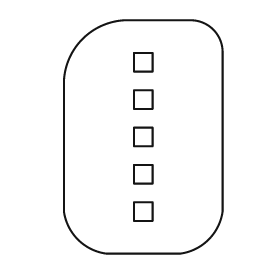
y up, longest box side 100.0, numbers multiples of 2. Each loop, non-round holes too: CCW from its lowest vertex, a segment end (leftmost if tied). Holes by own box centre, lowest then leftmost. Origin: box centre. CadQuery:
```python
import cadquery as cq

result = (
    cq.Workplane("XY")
    .moveTo(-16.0, -50.0)
    .lineTo(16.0, -50.0)
    .threePointArc((28.0, -44.0), (34.0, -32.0))
    .lineTo(34.0, 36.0)
    .threePointArc((30.0, 46.0), (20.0, 50.0))
    .lineTo(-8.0, 50.0)
    .threePointArc((-26.0, 42.0), (-34.0, 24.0))
    .lineTo(-34.0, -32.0)
    .threePointArc((-28.0, -44.0), (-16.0, -50.0))
    .close()
    .moveTo(-4.0, -36.0)
    .lineTo(4.0, -36.0)
    .lineTo(4.0, -28.0)
    .lineTo(-4.0, -28.0)
    .close()
    .moveTo(-4.0, -20.0)
    .lineTo(4.0, -20.0)
    .lineTo(4.0, -12.0)
    .lineTo(-4.0, -12.0)
    .close()
    .moveTo(-4.0, -4.0)
    .lineTo(4.0, -4.0)
    .lineTo(4.0, 4.0)
    .lineTo(-4.0, 4.0)
    .close()
    .moveTo(-4.0, 12.0)
    .lineTo(4.0, 12.0)
    .lineTo(4.0, 20.0)
    .lineTo(-4.0, 20.0)
    .close()
    .moveTo(-4.0, 28.0)
    .lineTo(4.0, 28.0)
    .lineTo(4.0, 36.0)
    .lineTo(-4.0, 36.0)
    .close()
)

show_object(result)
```